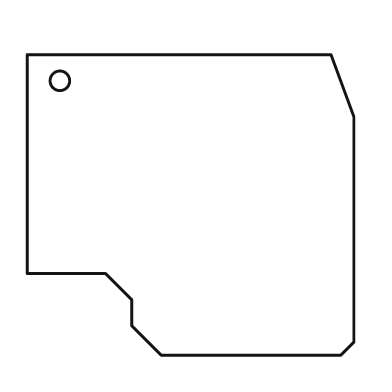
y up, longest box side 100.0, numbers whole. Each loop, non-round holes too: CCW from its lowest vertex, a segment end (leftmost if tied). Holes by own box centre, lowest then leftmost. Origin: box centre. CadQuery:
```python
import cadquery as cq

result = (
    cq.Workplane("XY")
    .moveTo(-9.0, -46.0)
    .lineTo(46.0, -46.0)
    .lineTo(50.0, -42.0)
    .lineTo(50.0, 27.0)
    .lineTo(43.0, 46.0)
    .lineTo(-50.0, 46.0)
    .lineTo(-50.0, -21.0)
    .lineTo(-26.0, -21.0)
    .lineTo(-18.0, -29.0)
    .lineTo(-18.0, -37.0)
    .close()
    .moveTo(-40.0, 38.0)
    .circle(3.0)
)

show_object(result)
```